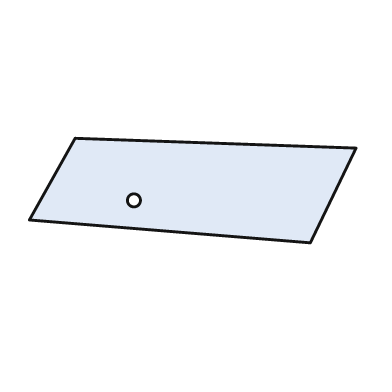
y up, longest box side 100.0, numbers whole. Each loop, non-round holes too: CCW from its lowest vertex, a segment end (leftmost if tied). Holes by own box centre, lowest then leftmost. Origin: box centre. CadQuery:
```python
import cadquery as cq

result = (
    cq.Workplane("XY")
    .moveTo(36.0, -16.0)
    .lineTo(50.0, 13.0)
    .lineTo(-36.0, 16.0)
    .lineTo(-50.0, -9.0)
    .close()
    .moveTo(-18.0, -3.0)
    .circle(2.0)
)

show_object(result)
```